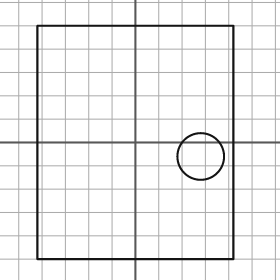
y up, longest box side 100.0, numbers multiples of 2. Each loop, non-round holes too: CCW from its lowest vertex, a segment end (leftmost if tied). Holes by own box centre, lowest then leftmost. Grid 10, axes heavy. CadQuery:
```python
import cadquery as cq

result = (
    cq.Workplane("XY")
    .moveTo(-42.0, -50.0)
    .lineTo(42.0, -50.0)
    .lineTo(42.0, 50.0)
    .lineTo(-42.0, 50.0)
    .close()
    .moveTo(28.0, -6.0)
    .circle(10.0)
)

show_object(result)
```